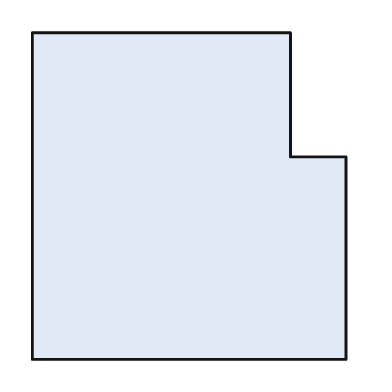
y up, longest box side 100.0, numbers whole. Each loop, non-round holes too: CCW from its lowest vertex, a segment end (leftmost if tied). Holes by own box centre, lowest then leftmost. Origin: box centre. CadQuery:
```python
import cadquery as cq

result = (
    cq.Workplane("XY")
    .moveTo(-48.0, -50.0)
    .lineTo(48.0, -50.0)
    .lineTo(48.0, 12.0)
    .lineTo(31.0, 12.0)
    .lineTo(31.0, 50.0)
    .lineTo(-48.0, 50.0)
    .close()
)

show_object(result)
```